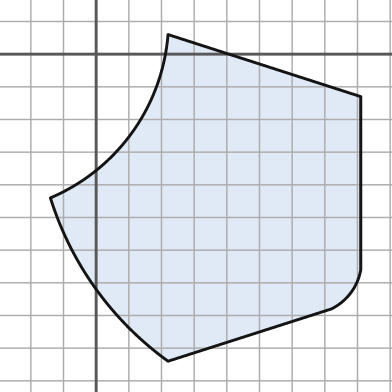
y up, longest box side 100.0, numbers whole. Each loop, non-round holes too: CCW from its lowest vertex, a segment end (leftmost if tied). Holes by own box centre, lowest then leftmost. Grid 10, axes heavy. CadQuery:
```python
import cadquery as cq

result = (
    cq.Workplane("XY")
    .moveTo(22.0, -94.0)
    .lineTo(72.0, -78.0)
    .threePointArc((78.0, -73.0), (81.0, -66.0))
    .lineTo(81.0, -13.0)
    .lineTo(22.0, 6.0)
    .threePointArc((11.0, -24.0), (-14.0, -44.0))
    .threePointArc((0.0, -72.0), (22.0, -94.0))
    .close()
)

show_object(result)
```